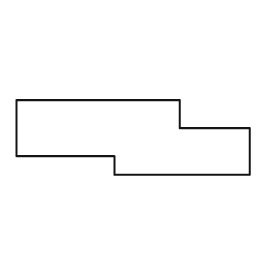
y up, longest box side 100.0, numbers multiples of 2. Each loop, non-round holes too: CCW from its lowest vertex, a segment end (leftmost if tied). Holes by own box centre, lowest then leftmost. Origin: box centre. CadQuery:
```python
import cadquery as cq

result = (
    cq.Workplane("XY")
    .moveTo(-8.0, -16.0)
    .lineTo(50.0, -16.0)
    .lineTo(50.0, 4.0)
    .lineTo(20.0, 4.0)
    .lineTo(20.0, 16.0)
    .lineTo(-50.0, 16.0)
    .lineTo(-50.0, -8.0)
    .lineTo(-8.0, -8.0)
    .close()
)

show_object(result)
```